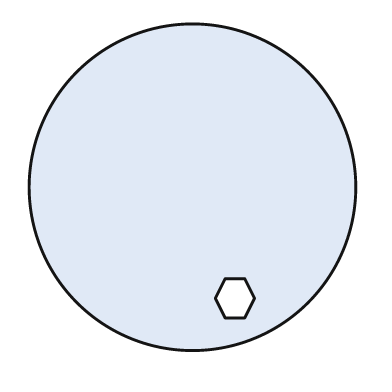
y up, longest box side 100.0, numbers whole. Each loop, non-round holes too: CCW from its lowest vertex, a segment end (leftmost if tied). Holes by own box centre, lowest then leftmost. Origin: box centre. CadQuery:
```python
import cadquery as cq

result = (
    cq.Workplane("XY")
    .moveTo(0.0, 0.0)
    .circle(50.0)
    .moveTo(10.0, -40.0)
    .lineTo(16.0, -40.0)
    .lineTo(19.0, -34.0)
    .lineTo(16.0, -28.0)
    .lineTo(10.0, -28.0)
    .lineTo(7.0, -34.0)
    .close()
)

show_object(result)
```